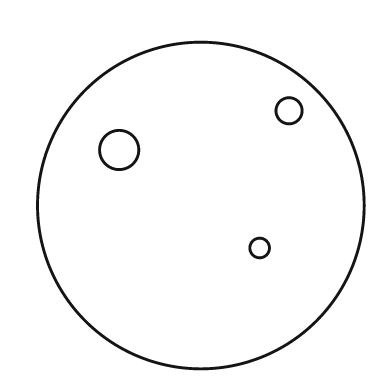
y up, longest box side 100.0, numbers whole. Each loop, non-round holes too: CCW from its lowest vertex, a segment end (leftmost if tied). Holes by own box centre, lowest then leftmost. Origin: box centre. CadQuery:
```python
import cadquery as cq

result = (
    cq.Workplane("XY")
    .moveTo(0.0, 0.0)
    .circle(50.0)
    .moveTo(18.0, -13.0)
    .circle(3.0)
    .moveTo(-25.0, 17.0)
    .circle(6.0)
    .moveTo(27.0, 29.0)
    .circle(4.0)
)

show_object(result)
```